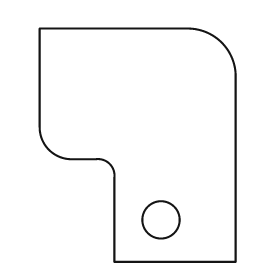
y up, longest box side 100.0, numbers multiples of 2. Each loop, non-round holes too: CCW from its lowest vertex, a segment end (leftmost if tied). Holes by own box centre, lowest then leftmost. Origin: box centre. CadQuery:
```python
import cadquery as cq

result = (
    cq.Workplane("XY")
    .moveTo(-10.0, -50.0)
    .lineTo(42.0, -50.0)
    .lineTo(42.0, 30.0)
    .threePointArc((36.0, 44.0), (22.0, 50.0))
    .lineTo(-42.0, 50.0)
    .lineTo(-42.0, 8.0)
    .threePointArc((-38.0, -2.0), (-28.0, -6.0))
    .lineTo(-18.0, -6.0)
    .threePointArc((-12.0, -8.0), (-10.0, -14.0))
    .close()
    .moveTo(10.0, -32.0)
    .circle(8.0)
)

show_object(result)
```